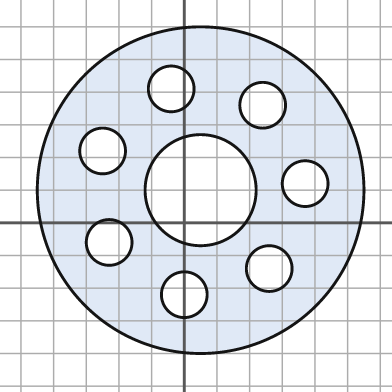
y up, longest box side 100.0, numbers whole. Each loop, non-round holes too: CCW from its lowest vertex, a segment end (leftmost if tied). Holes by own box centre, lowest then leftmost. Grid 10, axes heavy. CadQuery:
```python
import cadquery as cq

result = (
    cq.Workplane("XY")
    .moveTo(5.0, 10.0)
    .circle(50.0)
    .moveTo(0.0, -22.0)
    .circle(7.0)
    .moveTo(26.0, -14.0)
    .circle(7.0)
    .moveTo(-23.0, -6.0)
    .circle(7.0)
    .moveTo(5.0, 10.0)
    .circle(17.0)
    .moveTo(37.0, 12.0)
    .circle(7.0)
    .moveTo(-25.0, 22.0)
    .circle(7.0)
    .moveTo(24.0, 36.0)
    .circle(7.0)
    .moveTo(-4.0, 41.0)
    .circle(7.0)
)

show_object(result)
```